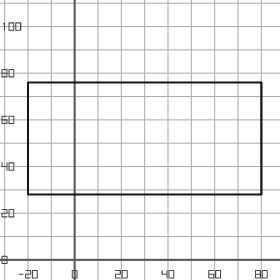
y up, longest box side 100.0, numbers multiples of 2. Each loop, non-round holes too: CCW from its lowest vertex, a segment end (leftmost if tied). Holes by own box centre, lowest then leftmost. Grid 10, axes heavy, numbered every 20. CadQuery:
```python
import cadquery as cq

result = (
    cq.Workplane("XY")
    .moveTo(-20.0, 28.0)
    .lineTo(80.0, 28.0)
    .lineTo(80.0, 76.0)
    .lineTo(-20.0, 76.0)
    .close()
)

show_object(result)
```